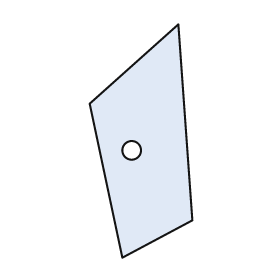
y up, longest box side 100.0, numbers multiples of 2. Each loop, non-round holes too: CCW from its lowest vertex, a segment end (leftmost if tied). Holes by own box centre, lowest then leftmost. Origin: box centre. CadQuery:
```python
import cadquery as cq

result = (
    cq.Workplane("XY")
    .moveTo(-8.0, -50.0)
    .lineTo(22.0, -34.0)
    .lineTo(16.0, 50.0)
    .lineTo(-22.0, 16.0)
    .close()
    .moveTo(-4.0, -4.0)
    .circle(4.0)
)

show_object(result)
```